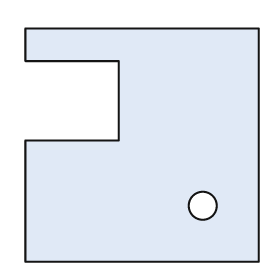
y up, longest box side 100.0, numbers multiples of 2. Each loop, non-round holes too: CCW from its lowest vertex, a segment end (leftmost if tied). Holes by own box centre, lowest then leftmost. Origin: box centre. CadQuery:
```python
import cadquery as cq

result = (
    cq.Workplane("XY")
    .moveTo(-50.0, -50.0)
    .lineTo(50.0, -50.0)
    .lineTo(50.0, 50.0)
    .lineTo(-50.0, 50.0)
    .lineTo(-50.0, 36.0)
    .lineTo(-10.0, 36.0)
    .lineTo(-10.0, 2.0)
    .lineTo(-50.0, 2.0)
    .close()
    .moveTo(26.0, -26.0)
    .circle(6.0)
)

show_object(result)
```